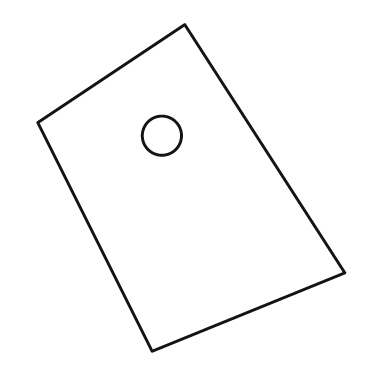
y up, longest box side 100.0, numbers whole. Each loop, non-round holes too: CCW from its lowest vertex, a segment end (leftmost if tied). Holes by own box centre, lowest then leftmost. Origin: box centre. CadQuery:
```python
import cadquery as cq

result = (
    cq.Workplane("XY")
    .moveTo(-12.0, -50.0)
    .lineTo(47.0, -26.0)
    .lineTo(-2.0, 50.0)
    .lineTo(-47.0, 20.0)
    .close()
    .moveTo(-9.0, 16.0)
    .circle(6.0)
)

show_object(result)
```